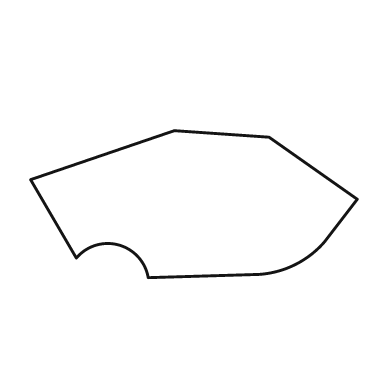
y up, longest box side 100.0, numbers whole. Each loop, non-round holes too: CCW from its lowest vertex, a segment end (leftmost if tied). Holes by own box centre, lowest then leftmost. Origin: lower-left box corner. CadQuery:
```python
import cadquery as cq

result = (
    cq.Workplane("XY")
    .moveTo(36.0, 0.0)
    .lineTo(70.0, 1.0)
    .threePointArc((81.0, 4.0), (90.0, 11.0))
    .lineTo(100.0, 24.0)
    .lineTo(73.0, 43.0)
    .lineTo(44.0, 45.0)
    .lineTo(0.0, 30.0)
    .lineTo(14.0, 6.0)
    .threePointArc((27.0, 10.0), (36.0, 0.0))
    .close()
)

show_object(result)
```